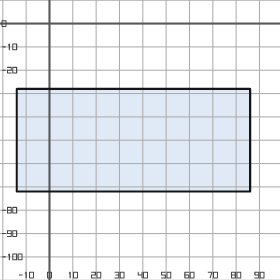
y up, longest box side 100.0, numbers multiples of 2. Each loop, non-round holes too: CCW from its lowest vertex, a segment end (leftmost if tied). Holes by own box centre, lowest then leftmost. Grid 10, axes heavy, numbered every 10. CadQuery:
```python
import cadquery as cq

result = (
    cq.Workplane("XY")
    .moveTo(-14.0, -72.0)
    .lineTo(86.0, -72.0)
    .lineTo(86.0, -28.0)
    .lineTo(-14.0, -28.0)
    .close()
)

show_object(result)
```